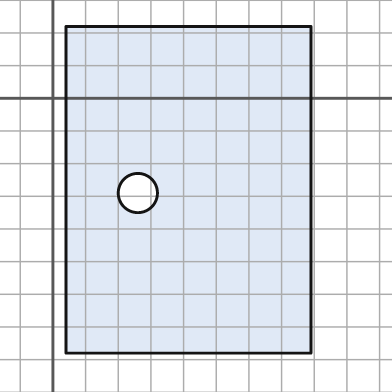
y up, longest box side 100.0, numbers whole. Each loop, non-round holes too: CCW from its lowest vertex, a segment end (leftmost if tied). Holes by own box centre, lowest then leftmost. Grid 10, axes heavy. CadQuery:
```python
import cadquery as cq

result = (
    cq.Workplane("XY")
    .moveTo(4.0, -78.0)
    .lineTo(79.0, -78.0)
    .lineTo(79.0, 22.0)
    .lineTo(4.0, 22.0)
    .close()
    .moveTo(26.0, -29.0)
    .circle(6.0)
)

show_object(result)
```